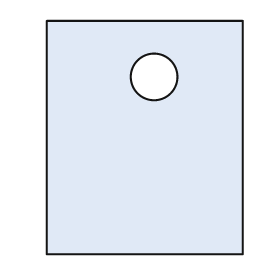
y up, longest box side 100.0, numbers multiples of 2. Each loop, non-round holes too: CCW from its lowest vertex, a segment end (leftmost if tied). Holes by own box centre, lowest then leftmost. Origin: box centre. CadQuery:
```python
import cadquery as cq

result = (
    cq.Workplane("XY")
    .moveTo(-42.0, -50.0)
    .lineTo(42.0, -50.0)
    .lineTo(42.0, 50.0)
    .lineTo(-42.0, 50.0)
    .close()
    .moveTo(4.0, 26.0)
    .circle(10.0)
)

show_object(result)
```